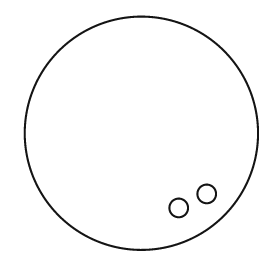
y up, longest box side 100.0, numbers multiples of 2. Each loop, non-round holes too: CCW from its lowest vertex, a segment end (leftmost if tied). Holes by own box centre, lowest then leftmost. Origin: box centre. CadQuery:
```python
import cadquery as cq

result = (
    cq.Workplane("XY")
    .moveTo(0.0, 0.0)
    .circle(50.0)
    .moveTo(16.0, -32.0)
    .circle(4.0)
    .moveTo(28.0, -26.0)
    .circle(4.0)
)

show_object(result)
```